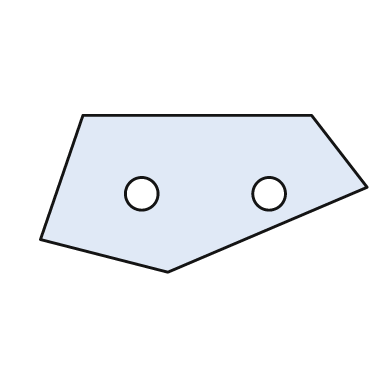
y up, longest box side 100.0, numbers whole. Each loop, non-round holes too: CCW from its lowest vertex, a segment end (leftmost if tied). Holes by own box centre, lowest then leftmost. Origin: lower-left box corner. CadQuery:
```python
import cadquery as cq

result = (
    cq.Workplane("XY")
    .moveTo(39.0, 0.0)
    .lineTo(100.0, 26.0)
    .lineTo(83.0, 48.0)
    .lineTo(13.0, 48.0)
    .lineTo(0.0, 10.0)
    .close()
    .moveTo(31.0, 24.0)
    .circle(5.0)
    .moveTo(70.0, 24.0)
    .circle(5.0)
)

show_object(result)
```